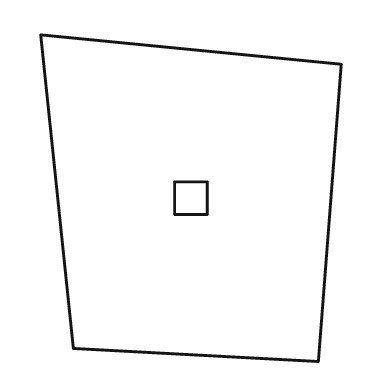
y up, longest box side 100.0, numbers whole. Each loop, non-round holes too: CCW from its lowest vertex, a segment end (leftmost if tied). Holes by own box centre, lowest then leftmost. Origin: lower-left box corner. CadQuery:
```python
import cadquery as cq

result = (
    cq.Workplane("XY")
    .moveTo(85.0, 0.0)
    .lineTo(92.0, 91.0)
    .lineTo(0.0, 100.0)
    .lineTo(10.0, 4.0)
    .close()
    .moveTo(41.0, 45.0)
    .lineTo(51.0, 45.0)
    .lineTo(51.0, 55.0)
    .lineTo(41.0, 55.0)
    .close()
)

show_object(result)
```